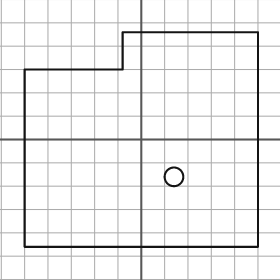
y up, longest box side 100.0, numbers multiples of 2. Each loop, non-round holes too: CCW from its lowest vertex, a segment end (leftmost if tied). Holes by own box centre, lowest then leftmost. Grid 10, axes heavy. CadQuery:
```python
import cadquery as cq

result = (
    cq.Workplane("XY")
    .moveTo(-50.0, -46.0)
    .lineTo(50.0, -46.0)
    .lineTo(50.0, 46.0)
    .lineTo(-8.0, 46.0)
    .lineTo(-8.0, 30.0)
    .lineTo(-50.0, 30.0)
    .close()
    .moveTo(14.0, -16.0)
    .circle(4.0)
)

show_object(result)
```